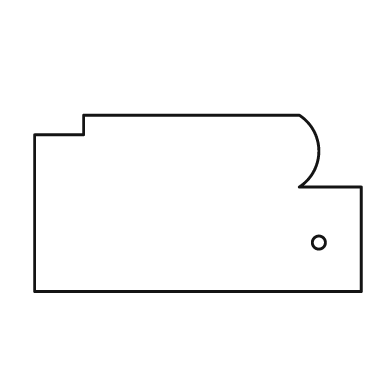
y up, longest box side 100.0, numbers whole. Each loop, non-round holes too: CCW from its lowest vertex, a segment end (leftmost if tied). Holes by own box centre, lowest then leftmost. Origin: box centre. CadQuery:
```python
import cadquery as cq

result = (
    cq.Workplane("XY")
    .moveTo(-50.0, -27.0)
    .lineTo(50.0, -27.0)
    .lineTo(50.0, 5.0)
    .lineTo(31.0, 5.0)
    .threePointArc((37.0, 16.0), (31.0, 27.0))
    .lineTo(-35.0, 27.0)
    .lineTo(-35.0, 21.0)
    .lineTo(-50.0, 21.0)
    .close()
    .moveTo(37.0, -12.0)
    .circle(2.0)
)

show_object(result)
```